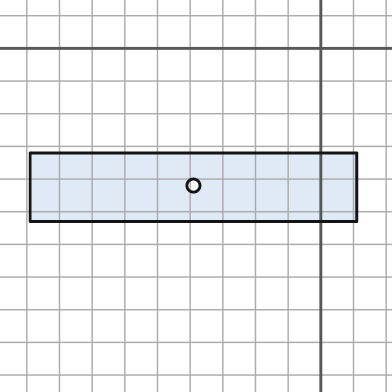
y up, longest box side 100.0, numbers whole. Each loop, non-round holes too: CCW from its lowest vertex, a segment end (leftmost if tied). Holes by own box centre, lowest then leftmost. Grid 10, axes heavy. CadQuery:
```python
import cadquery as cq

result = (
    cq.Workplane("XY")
    .moveTo(-89.0, -53.0)
    .lineTo(11.0, -53.0)
    .lineTo(11.0, -32.0)
    .lineTo(-89.0, -32.0)
    .close()
    .moveTo(-39.0, -42.0)
    .circle(2.0)
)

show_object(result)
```